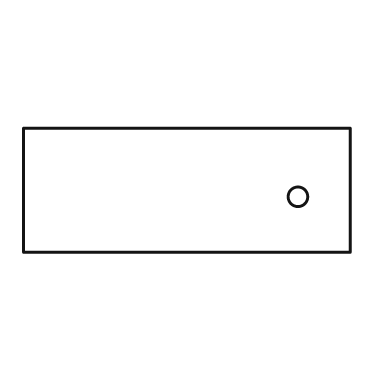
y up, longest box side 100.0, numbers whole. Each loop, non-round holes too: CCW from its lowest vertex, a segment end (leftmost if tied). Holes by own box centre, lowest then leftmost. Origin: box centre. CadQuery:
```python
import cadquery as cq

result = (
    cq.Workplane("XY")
    .moveTo(-50.0, -19.0)
    .lineTo(50.0, -19.0)
    .lineTo(50.0, 19.0)
    .lineTo(-50.0, 19.0)
    .close()
    .moveTo(34.0, -2.0)
    .circle(3.0)
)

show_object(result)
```